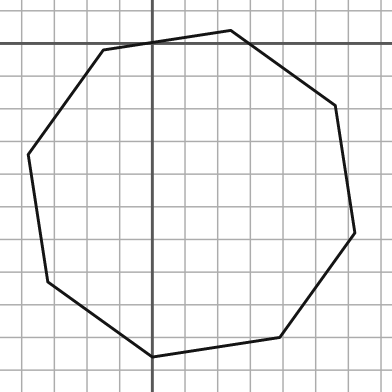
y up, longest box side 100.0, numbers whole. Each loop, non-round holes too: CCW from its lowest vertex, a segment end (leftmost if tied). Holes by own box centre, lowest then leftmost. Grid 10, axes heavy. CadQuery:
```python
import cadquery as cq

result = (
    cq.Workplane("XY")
    .moveTo(0.0, -96.0)
    .lineTo(39.0, -90.0)
    .lineTo(62.0, -58.0)
    .lineTo(56.0, -19.0)
    .lineTo(24.0, 4.0)
    .lineTo(-15.0, -2.0)
    .lineTo(-38.0, -34.0)
    .lineTo(-32.0, -73.0)
    .close()
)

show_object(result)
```